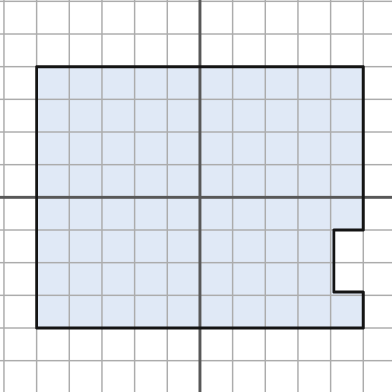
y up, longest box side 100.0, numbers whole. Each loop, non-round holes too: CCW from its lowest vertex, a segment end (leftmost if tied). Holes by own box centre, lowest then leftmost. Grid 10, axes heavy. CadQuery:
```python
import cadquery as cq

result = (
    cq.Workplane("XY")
    .moveTo(-50.0, -40.0)
    .lineTo(50.0, -40.0)
    .lineTo(50.0, -29.0)
    .lineTo(41.0, -29.0)
    .lineTo(41.0, -10.0)
    .lineTo(50.0, -10.0)
    .lineTo(50.0, 40.0)
    .lineTo(-50.0, 40.0)
    .close()
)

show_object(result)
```